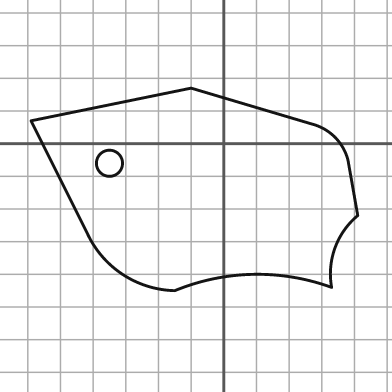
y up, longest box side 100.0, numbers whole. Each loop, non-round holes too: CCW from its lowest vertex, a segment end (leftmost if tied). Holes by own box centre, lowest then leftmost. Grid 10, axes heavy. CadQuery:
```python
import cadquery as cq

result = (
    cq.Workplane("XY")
    .moveTo(-15.0, -45.0)
    .threePointArc((9.0, -40.0), (33.0, -44.0))
    .threePointArc((34.0, -32.0), (41.0, -22.0))
    .lineTo(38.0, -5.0)
    .threePointArc((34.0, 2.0), (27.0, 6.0))
    .lineTo(-10.0, 17.0)
    .lineTo(-59.0, 7.0)
    .lineTo(-42.0, -27.0)
    .threePointArc((-31.0, -40.0), (-15.0, -45.0))
    .close()
    .moveTo(-35.0, -6.0)
    .circle(4.0)
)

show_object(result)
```